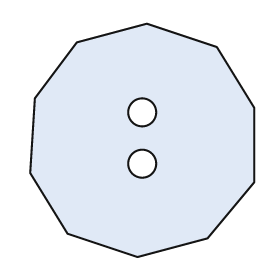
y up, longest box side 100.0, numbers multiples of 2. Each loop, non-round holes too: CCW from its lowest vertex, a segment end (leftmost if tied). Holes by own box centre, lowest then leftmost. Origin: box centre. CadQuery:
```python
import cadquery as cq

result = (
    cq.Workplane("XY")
    .moveTo(-2.0, -50.0)
    .lineTo(28.0, -42.0)
    .lineTo(48.0, -18.0)
    .lineTo(48.0, 14.0)
    .lineTo(32.0, 40.0)
    .lineTo(2.0, 50.0)
    .lineTo(-28.0, 42.0)
    .lineTo(-46.0, 18.0)
    .lineTo(-48.0, -14.0)
    .lineTo(-32.0, -40.0)
    .close()
    .moveTo(0.0, -10.0)
    .circle(6.0)
    .moveTo(0.0, 12.0)
    .circle(6.0)
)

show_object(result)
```